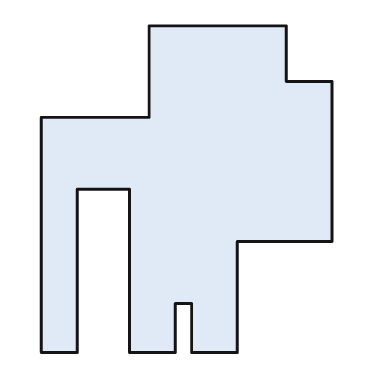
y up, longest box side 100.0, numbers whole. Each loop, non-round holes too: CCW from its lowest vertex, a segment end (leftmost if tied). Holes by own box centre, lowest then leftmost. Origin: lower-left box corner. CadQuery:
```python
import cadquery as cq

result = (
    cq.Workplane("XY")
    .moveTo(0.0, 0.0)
    .lineTo(11.0, 0.0)
    .lineTo(11.0, 50.0)
    .lineTo(27.0, 50.0)
    .lineTo(27.0, 0.0)
    .lineTo(41.0, 0.0)
    .lineTo(41.0, 15.0)
    .lineTo(46.0, 15.0)
    .lineTo(46.0, 0.0)
    .lineTo(60.0, 0.0)
    .lineTo(60.0, 34.0)
    .lineTo(89.0, 34.0)
    .lineTo(89.0, 83.0)
    .lineTo(75.0, 83.0)
    .lineTo(75.0, 100.0)
    .lineTo(33.0, 100.0)
    .lineTo(33.0, 72.0)
    .lineTo(0.0, 72.0)
    .close()
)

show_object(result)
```